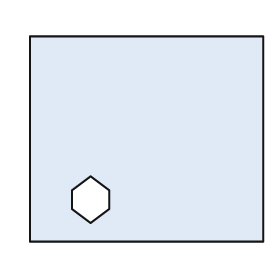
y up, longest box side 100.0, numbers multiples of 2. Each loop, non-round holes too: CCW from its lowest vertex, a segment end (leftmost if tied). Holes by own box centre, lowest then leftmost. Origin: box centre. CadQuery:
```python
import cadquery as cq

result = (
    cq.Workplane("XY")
    .moveTo(-50.0, -44.0)
    .lineTo(50.0, -44.0)
    .lineTo(50.0, 44.0)
    .lineTo(-50.0, 44.0)
    .close()
    .moveTo(-24.0, -36.0)
    .lineTo(-16.0, -30.0)
    .lineTo(-16.0, -22.0)
    .lineTo(-24.0, -16.0)
    .lineTo(-32.0, -22.0)
    .lineTo(-32.0, -30.0)
    .close()
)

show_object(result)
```